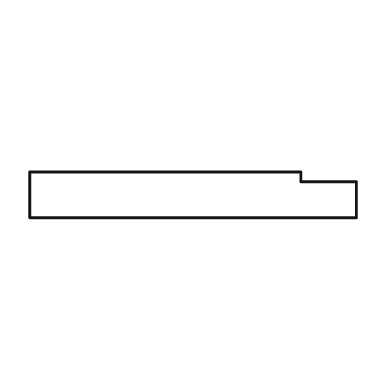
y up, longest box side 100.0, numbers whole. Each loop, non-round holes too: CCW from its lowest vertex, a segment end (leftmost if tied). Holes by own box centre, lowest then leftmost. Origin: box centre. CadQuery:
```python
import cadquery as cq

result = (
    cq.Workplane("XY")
    .moveTo(-50.0, -7.0)
    .lineTo(50.0, -7.0)
    .lineTo(50.0, 4.0)
    .lineTo(33.0, 4.0)
    .lineTo(33.0, 7.0)
    .lineTo(-50.0, 7.0)
    .close()
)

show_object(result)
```